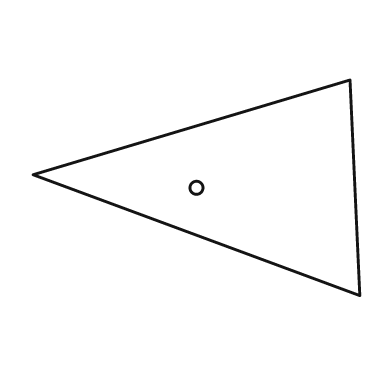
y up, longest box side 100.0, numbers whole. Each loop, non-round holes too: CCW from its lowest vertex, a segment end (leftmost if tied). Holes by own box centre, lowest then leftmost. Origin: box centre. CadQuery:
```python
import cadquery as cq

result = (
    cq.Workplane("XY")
    .moveTo(50.0, -33.0)
    .lineTo(47.0, 33.0)
    .lineTo(-50.0, 4.0)
    .close()
    .moveTo(0.0, 0.0)
    .circle(2.0)
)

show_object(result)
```